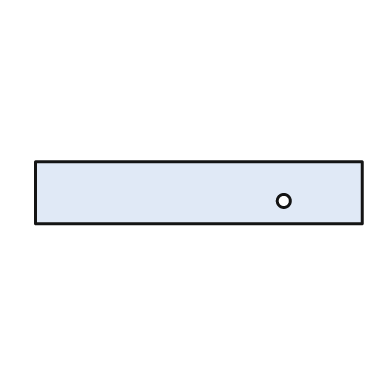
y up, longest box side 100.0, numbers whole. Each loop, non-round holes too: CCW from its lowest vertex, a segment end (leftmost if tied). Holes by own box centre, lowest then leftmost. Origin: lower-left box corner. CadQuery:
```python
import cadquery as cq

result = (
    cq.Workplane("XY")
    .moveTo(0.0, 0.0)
    .lineTo(100.0, 0.0)
    .lineTo(100.0, 19.0)
    .lineTo(0.0, 19.0)
    .close()
    .moveTo(76.0, 7.0)
    .circle(2.0)
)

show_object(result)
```